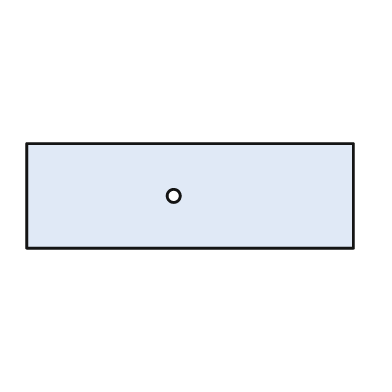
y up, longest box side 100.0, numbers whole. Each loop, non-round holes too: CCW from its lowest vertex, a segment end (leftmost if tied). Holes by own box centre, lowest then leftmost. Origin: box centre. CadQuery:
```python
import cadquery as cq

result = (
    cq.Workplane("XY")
    .moveTo(-50.0, -16.0)
    .lineTo(50.0, -16.0)
    .lineTo(50.0, 16.0)
    .lineTo(-50.0, 16.0)
    .close()
    .moveTo(-5.0, 0.0)
    .circle(2.0)
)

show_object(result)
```